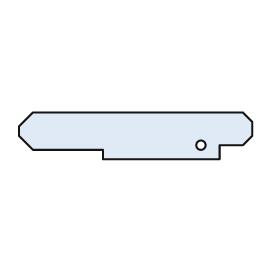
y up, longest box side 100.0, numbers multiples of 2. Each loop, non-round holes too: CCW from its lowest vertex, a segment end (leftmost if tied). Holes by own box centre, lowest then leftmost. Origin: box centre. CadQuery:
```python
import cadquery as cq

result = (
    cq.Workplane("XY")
    .moveTo(-14.0, -10.0)
    .lineTo(36.0, -10.0)
    .lineTo(36.0, -4.0)
    .lineTo(46.0, -4.0)
    .lineTo(50.0, 0.0)
    .lineTo(50.0, 6.0)
    .lineTo(46.0, 10.0)
    .lineTo(-44.0, 10.0)
    .lineTo(-50.0, 4.0)
    .lineTo(-50.0, 0.0)
    .lineTo(-44.0, -6.0)
    .lineTo(-14.0, -6.0)
    .close()
    .moveTo(28.0, -4.0)
    .circle(2.0)
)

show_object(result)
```